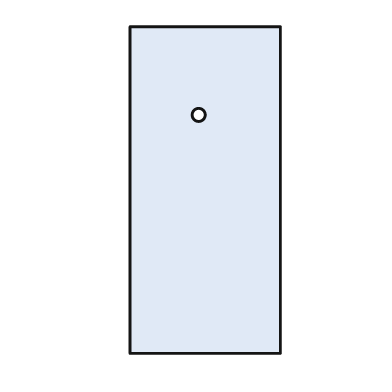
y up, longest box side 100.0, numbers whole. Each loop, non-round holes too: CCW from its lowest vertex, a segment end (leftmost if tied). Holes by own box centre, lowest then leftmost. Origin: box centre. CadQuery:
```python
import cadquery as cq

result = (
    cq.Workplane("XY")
    .moveTo(-23.0, -50.0)
    .lineTo(23.0, -50.0)
    .lineTo(23.0, 50.0)
    .lineTo(-23.0, 50.0)
    .close()
    .moveTo(-2.0, 23.0)
    .circle(2.0)
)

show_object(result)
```